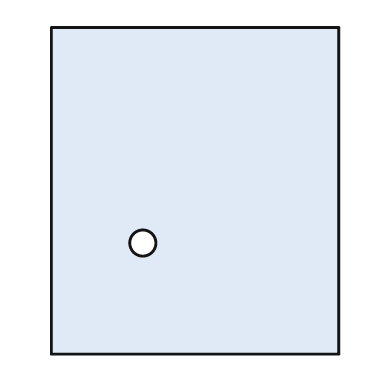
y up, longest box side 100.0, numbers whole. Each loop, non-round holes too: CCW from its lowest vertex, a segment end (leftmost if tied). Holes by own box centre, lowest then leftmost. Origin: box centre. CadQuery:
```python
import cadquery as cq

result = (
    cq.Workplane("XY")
    .moveTo(-44.0, -50.0)
    .lineTo(44.0, -50.0)
    .lineTo(44.0, 50.0)
    .lineTo(-44.0, 50.0)
    .close()
    .moveTo(-16.0, -16.0)
    .circle(4.0)
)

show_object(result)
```